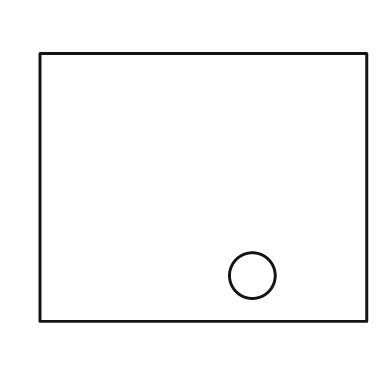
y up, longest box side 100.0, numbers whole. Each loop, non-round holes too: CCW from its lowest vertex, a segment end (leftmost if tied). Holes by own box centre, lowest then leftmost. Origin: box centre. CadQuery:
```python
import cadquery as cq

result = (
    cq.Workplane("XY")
    .moveTo(-50.0, -41.0)
    .lineTo(50.0, -41.0)
    .lineTo(50.0, 41.0)
    .lineTo(-50.0, 41.0)
    .close()
    .moveTo(15.0, -27.0)
    .circle(7.0)
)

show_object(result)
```